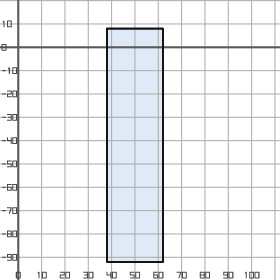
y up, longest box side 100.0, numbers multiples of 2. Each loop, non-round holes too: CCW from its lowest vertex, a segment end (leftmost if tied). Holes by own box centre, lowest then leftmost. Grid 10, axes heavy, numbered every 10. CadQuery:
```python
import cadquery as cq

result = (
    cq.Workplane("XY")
    .moveTo(38.0, -92.0)
    .lineTo(62.0, -92.0)
    .lineTo(62.0, 8.0)
    .lineTo(38.0, 8.0)
    .close()
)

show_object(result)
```